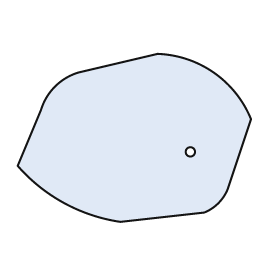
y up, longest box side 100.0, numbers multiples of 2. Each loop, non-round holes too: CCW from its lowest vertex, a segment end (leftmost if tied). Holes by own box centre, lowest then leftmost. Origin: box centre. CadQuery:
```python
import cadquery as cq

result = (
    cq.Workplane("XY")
    .moveTo(-6.0, -36.0)
    .lineTo(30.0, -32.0)
    .threePointArc((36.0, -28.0), (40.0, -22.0))
    .lineTo(50.0, 8.0)
    .threePointArc((34.0, 28.0), (10.0, 36.0))
    .lineTo(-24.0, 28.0)
    .threePointArc((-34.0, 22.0), (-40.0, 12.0))
    .lineTo(-50.0, -12.0)
    .threePointArc((-30.0, -28.0), (-6.0, -36.0))
    .close()
    .moveTo(24.0, -6.0)
    .circle(2.0)
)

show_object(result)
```